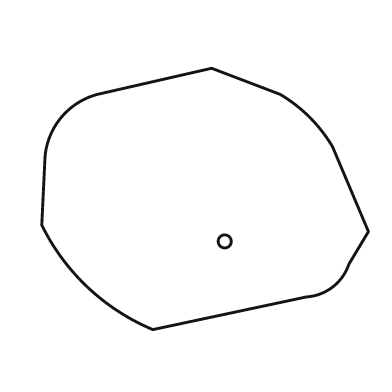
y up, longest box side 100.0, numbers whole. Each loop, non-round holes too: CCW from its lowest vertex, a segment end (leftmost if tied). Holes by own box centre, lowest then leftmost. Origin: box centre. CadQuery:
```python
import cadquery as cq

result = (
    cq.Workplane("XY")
    .moveTo(-16.0, -40.0)
    .lineTo(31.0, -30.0)
    .threePointArc((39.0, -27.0), (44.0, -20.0))
    .lineTo(50.0, -10.0)
    .lineTo(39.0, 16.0)
    .threePointArc((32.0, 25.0), (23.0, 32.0))
    .lineTo(2.0, 40.0)
    .lineTo(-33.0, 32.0)
    .threePointArc((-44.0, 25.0), (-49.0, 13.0))
    .lineTo(-50.0, -8.0)
    .threePointArc((-36.0, -27.0), (-16.0, -40.0))
    .close()
    .moveTo(6.0, -13.0)
    .circle(2.0)
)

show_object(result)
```